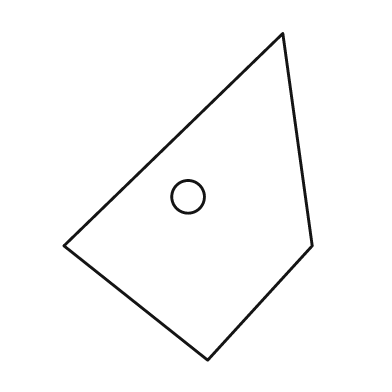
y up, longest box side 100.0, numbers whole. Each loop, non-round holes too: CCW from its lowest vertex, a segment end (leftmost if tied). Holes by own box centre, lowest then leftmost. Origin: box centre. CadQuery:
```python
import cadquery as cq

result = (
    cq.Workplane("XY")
    .moveTo(6.0, -50.0)
    .lineTo(38.0, -15.0)
    .lineTo(29.0, 50.0)
    .lineTo(-38.0, -15.0)
    .close()
    .moveTo(0.0, 0.0)
    .circle(5.0)
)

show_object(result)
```